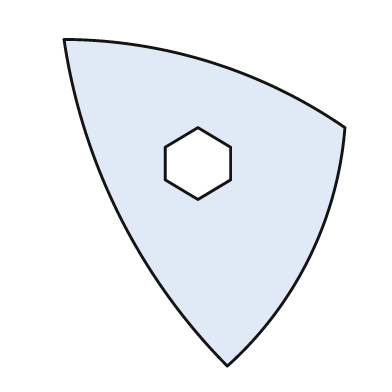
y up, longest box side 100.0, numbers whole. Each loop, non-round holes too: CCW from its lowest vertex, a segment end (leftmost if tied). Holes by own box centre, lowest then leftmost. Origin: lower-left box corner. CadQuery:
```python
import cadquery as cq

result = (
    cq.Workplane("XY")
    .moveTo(50.0, 0.0)
    .threePointArc((75.0, 33.0), (86.0, 73.0))
    .threePointArc((45.0, 93.0), (0.0, 100.0))
    .threePointArc((17.0, 46.0), (50.0, 0.0))
    .close()
    .moveTo(41.0, 51.0)
    .lineTo(51.0, 57.0)
    .lineTo(51.0, 67.0)
    .lineTo(41.0, 73.0)
    .lineTo(31.0, 67.0)
    .lineTo(31.0, 57.0)
    .close()
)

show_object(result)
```